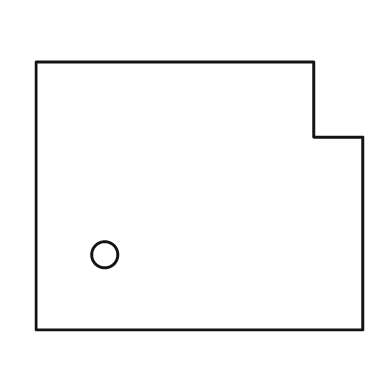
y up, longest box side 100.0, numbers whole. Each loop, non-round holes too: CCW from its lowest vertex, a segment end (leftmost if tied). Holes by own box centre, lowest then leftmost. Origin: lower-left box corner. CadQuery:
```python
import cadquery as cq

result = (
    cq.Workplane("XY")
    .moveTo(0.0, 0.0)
    .lineTo(100.0, 0.0)
    .lineTo(100.0, 59.0)
    .lineTo(85.0, 59.0)
    .lineTo(85.0, 82.0)
    .lineTo(0.0, 82.0)
    .close()
    .moveTo(21.0, 23.0)
    .circle(4.0)
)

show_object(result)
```